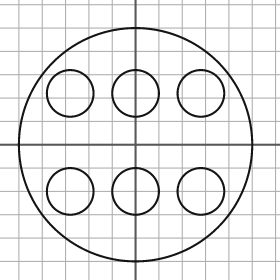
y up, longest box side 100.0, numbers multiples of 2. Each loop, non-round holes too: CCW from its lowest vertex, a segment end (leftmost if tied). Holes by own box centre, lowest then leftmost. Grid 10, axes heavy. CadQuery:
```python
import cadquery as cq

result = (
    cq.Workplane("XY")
    .moveTo(0.0, 0.0)
    .circle(50.0)
    .moveTo(-28.0, -20.0)
    .circle(10.0)
    .moveTo(0.0, -20.0)
    .circle(10.0)
    .moveTo(28.0, -20.0)
    .circle(10.0)
    .moveTo(-28.0, 22.0)
    .circle(10.0)
    .moveTo(0.0, 22.0)
    .circle(10.0)
    .moveTo(28.0, 22.0)
    .circle(10.0)
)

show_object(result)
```